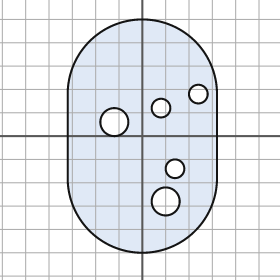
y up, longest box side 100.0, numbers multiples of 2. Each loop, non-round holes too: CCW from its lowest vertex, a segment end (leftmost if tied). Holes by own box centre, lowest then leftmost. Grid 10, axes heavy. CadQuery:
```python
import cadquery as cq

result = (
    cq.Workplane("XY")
    .moveTo(-32.0, -18.0)
    .threePointArc((0.0, -50.0), (32.0, -18.0))
    .lineTo(32.0, 18.0)
    .threePointArc((0.0, 50.0), (-32.0, 18.0))
    .close()
    .moveTo(10.0, -28.0)
    .circle(6.0)
    .moveTo(14.0, -14.0)
    .circle(4.0)
    .moveTo(-12.0, 6.0)
    .circle(6.0)
    .moveTo(8.0, 12.0)
    .circle(4.0)
    .moveTo(24.0, 18.0)
    .circle(4.0)
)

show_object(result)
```